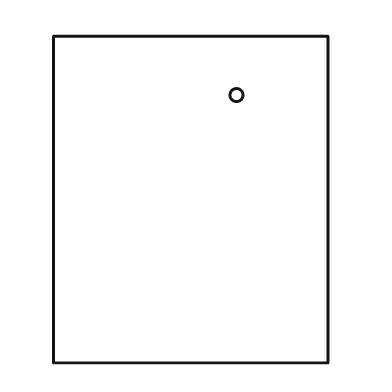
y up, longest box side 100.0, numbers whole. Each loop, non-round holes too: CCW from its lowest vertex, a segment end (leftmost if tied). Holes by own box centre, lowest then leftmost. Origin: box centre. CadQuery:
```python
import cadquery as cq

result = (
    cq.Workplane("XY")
    .moveTo(-42.0, -50.0)
    .lineTo(42.0, -50.0)
    .lineTo(42.0, 50.0)
    .lineTo(-42.0, 50.0)
    .close()
    .moveTo(14.0, 32.0)
    .circle(2.0)
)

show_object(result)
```